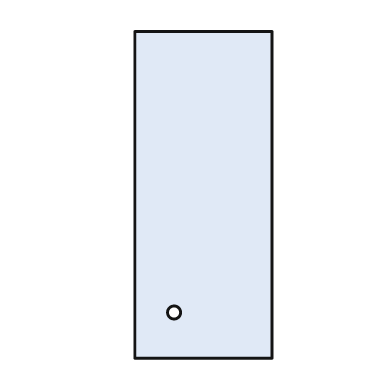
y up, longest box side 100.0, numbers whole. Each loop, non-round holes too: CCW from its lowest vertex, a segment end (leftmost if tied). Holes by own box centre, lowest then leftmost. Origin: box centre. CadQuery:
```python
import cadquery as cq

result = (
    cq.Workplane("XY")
    .moveTo(-21.0, -50.0)
    .lineTo(21.0, -50.0)
    .lineTo(21.0, 50.0)
    .lineTo(-21.0, 50.0)
    .close()
    .moveTo(-9.0, -36.0)
    .circle(2.0)
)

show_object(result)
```